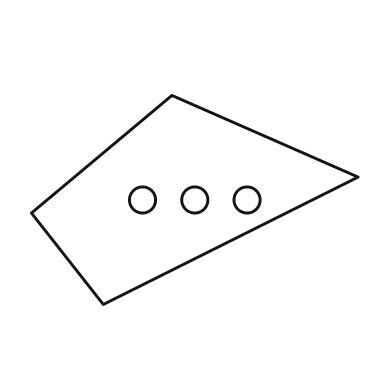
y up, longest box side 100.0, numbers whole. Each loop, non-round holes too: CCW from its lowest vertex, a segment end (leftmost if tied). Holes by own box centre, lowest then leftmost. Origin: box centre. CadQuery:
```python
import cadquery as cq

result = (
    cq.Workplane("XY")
    .moveTo(-28.0, -32.0)
    .lineTo(50.0, 7.0)
    .lineTo(-7.0, 32.0)
    .lineTo(-50.0, -4.0)
    .close()
    .moveTo(-16.0, 0.0)
    .circle(4.0)
    .moveTo(0.0, 0.0)
    .circle(4.0)
    .moveTo(16.0, 0.0)
    .circle(4.0)
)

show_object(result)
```